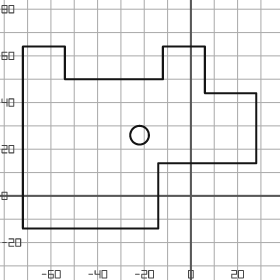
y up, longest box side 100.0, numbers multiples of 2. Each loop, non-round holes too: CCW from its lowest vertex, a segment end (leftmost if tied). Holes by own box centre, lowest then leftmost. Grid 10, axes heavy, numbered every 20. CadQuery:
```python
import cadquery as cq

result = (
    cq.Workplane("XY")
    .moveTo(-72.0, -14.0)
    .lineTo(-14.0, -14.0)
    .lineTo(-14.0, 14.0)
    .lineTo(28.0, 14.0)
    .lineTo(28.0, 44.0)
    .lineTo(6.0, 44.0)
    .lineTo(6.0, 64.0)
    .lineTo(-12.0, 64.0)
    .lineTo(-12.0, 50.0)
    .lineTo(-54.0, 50.0)
    .lineTo(-54.0, 64.0)
    .lineTo(-72.0, 64.0)
    .close()
    .moveTo(-22.0, 26.0)
    .circle(4.0)
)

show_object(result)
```